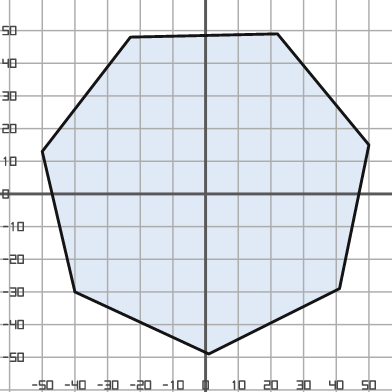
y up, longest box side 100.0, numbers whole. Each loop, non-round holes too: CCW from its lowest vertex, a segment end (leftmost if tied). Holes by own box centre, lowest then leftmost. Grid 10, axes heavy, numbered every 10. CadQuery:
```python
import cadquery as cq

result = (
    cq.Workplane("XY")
    .moveTo(1.0, -49.0)
    .lineTo(41.0, -29.0)
    .lineTo(50.0, 15.0)
    .lineTo(22.0, 49.0)
    .lineTo(-23.0, 48.0)
    .lineTo(-50.0, 13.0)
    .lineTo(-40.0, -30.0)
    .close()
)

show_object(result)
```